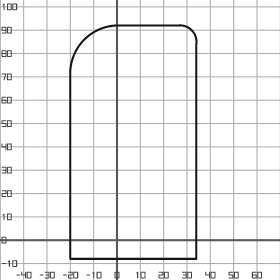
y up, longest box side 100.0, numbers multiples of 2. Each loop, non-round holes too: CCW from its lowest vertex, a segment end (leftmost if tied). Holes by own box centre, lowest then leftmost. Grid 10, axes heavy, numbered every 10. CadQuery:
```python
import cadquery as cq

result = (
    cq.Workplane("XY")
    .moveTo(-20.0, -8.0)
    .lineTo(34.0, -8.0)
    .lineTo(34.0, 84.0)
    .threePointArc((32.0, 90.0), (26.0, 92.0))
    .lineTo(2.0, 92.0)
    .threePointArc((-14.0, 86.0), (-20.0, 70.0))
    .close()
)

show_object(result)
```